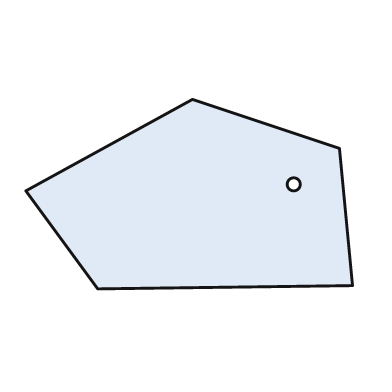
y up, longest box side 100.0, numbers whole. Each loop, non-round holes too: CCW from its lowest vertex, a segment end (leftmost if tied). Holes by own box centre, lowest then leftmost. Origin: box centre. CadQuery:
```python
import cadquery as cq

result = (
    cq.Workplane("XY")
    .moveTo(-28.0, -29.0)
    .lineTo(50.0, -28.0)
    .lineTo(46.0, 14.0)
    .lineTo(1.0, 29.0)
    .lineTo(-50.0, 1.0)
    .close()
    .moveTo(32.0, 3.0)
    .circle(2.0)
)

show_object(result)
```